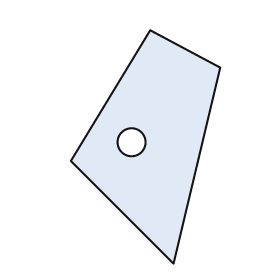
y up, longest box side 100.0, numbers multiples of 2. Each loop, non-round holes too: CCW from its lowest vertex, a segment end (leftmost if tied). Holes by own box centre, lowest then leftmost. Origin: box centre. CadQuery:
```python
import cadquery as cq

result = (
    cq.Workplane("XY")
    .moveTo(12.0, -50.0)
    .lineTo(32.0, 34.0)
    .lineTo(2.0, 50.0)
    .lineTo(-32.0, -6.0)
    .close()
    .moveTo(-6.0, 2.0)
    .circle(6.0)
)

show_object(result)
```